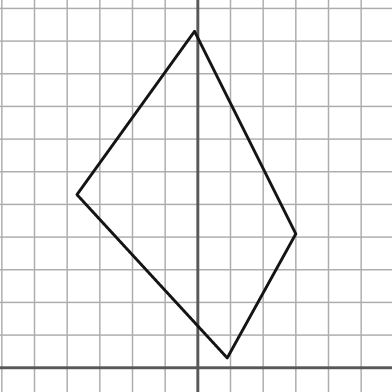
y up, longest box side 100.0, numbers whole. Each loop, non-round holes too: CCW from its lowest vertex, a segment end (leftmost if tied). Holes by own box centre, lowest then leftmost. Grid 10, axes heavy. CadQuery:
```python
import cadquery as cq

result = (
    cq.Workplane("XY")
    .moveTo(9.0, 3.0)
    .lineTo(30.0, 41.0)
    .lineTo(-1.0, 103.0)
    .lineTo(-37.0, 53.0)
    .close()
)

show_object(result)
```